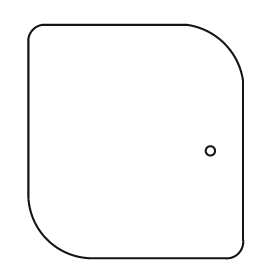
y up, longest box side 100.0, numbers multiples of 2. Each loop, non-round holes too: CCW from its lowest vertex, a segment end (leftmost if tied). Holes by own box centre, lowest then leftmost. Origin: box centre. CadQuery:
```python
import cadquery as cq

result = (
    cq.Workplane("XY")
    .moveTo(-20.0, -50.0)
    .lineTo(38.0, -50.0)
    .threePointArc((44.0, -48.0), (46.0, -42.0))
    .lineTo(46.0, 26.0)
    .threePointArc((38.0, 42.0), (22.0, 50.0))
    .lineTo(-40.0, 50.0)
    .threePointArc((-44.0, 48.0), (-46.0, 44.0))
    .lineTo(-46.0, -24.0)
    .threePointArc((-38.0, -42.0), (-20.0, -50.0))
    .close()
    .moveTo(32.0, -4.0)
    .circle(2.0)
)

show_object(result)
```